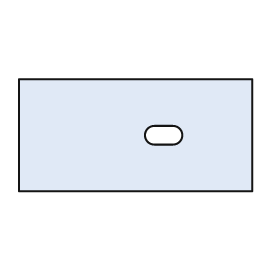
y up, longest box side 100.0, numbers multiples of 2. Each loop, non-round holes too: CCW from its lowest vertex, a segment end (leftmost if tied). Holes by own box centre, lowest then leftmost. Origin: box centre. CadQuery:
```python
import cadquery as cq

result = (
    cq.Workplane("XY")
    .moveTo(-50.0, -24.0)
    .lineTo(50.0, -24.0)
    .lineTo(50.0, 24.0)
    .lineTo(-50.0, 24.0)
    .close()
    .moveTo(8.0, -4.0)
    .lineTo(16.0, -4.0)
    .threePointArc((20.0, 0.0), (16.0, 4.0))
    .lineTo(8.0, 4.0)
    .threePointArc((4.0, 0.0), (8.0, -4.0))
    .close()
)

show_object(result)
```